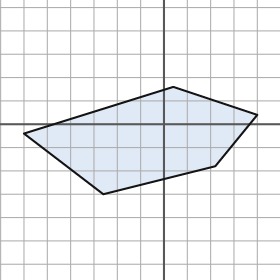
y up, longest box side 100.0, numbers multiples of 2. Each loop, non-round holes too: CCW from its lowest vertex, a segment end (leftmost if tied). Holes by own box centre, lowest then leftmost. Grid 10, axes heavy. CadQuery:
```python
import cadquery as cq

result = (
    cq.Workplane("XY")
    .moveTo(-26.0, -30.0)
    .lineTo(22.0, -18.0)
    .lineTo(40.0, 4.0)
    .lineTo(4.0, 16.0)
    .lineTo(-60.0, -4.0)
    .close()
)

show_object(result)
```